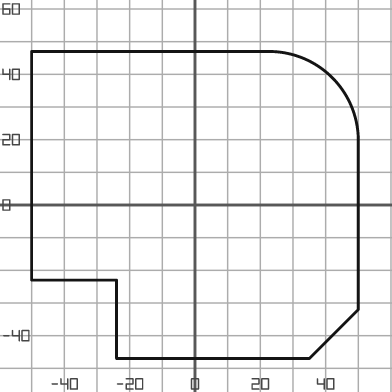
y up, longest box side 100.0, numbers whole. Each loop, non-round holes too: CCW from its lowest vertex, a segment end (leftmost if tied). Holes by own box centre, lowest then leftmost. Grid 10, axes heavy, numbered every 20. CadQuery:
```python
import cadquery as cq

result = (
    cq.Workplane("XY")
    .moveTo(-24.0, -47.0)
    .lineTo(35.0, -47.0)
    .lineTo(50.0, -32.0)
    .lineTo(50.0, 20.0)
    .threePointArc((42.0, 39.0), (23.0, 47.0))
    .lineTo(-50.0, 47.0)
    .lineTo(-50.0, -23.0)
    .lineTo(-24.0, -23.0)
    .close()
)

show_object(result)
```